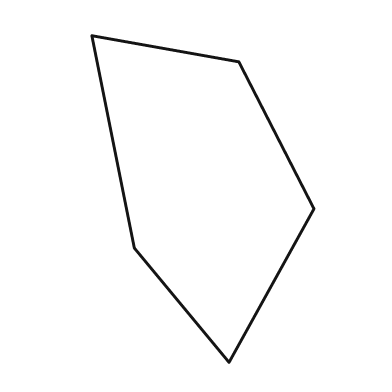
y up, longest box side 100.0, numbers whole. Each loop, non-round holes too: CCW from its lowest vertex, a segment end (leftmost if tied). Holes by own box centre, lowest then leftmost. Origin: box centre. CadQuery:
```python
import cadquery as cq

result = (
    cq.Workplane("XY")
    .moveTo(8.0, -50.0)
    .lineTo(34.0, -3.0)
    .lineTo(11.0, 42.0)
    .lineTo(-34.0, 50.0)
    .lineTo(-21.0, -15.0)
    .close()
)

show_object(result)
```